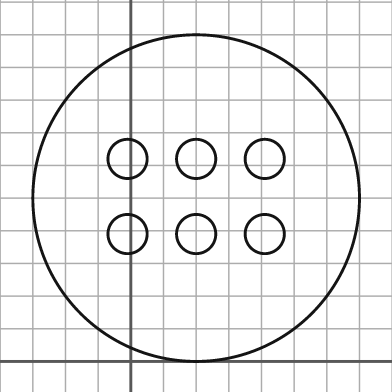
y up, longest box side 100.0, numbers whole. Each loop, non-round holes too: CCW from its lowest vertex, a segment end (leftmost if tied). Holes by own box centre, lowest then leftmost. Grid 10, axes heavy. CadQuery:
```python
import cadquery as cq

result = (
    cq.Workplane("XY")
    .moveTo(20.0, 50.0)
    .circle(50.0)
    .moveTo(-1.0, 39.0)
    .circle(6.0)
    .moveTo(20.0, 39.0)
    .circle(6.0)
    .moveTo(41.0, 39.0)
    .circle(6.0)
    .moveTo(-1.0, 62.0)
    .circle(6.0)
    .moveTo(20.0, 62.0)
    .circle(6.0)
    .moveTo(41.0, 62.0)
    .circle(6.0)
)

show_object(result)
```